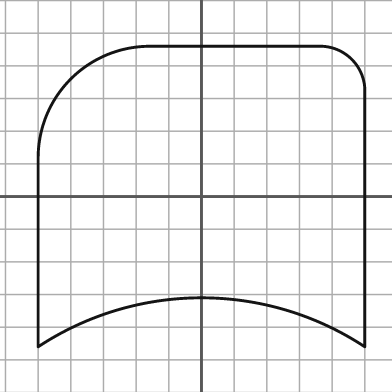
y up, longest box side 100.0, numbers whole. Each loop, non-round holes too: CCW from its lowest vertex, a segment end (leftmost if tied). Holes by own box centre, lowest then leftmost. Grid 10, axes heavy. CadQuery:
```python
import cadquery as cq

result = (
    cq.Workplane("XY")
    .moveTo(-50.0, -46.0)
    .threePointArc((0.0, -31.0), (50.0, -46.0))
    .lineTo(50.0, 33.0)
    .threePointArc((46.0, 42.0), (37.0, 46.0))
    .lineTo(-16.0, 46.0)
    .threePointArc((-40.0, 36.0), (-50.0, 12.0))
    .close()
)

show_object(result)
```